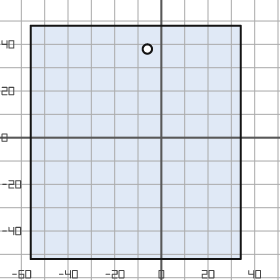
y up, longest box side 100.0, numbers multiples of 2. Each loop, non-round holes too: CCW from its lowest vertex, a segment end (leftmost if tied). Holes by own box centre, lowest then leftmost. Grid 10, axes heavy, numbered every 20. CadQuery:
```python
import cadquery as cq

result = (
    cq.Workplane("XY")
    .moveTo(-56.0, -52.0)
    .lineTo(34.0, -52.0)
    .lineTo(34.0, 48.0)
    .lineTo(-56.0, 48.0)
    .close()
    .moveTo(-6.0, 38.0)
    .circle(2.0)
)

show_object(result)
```